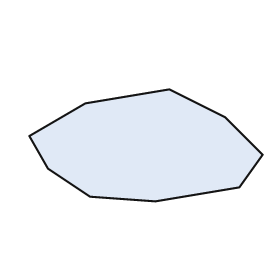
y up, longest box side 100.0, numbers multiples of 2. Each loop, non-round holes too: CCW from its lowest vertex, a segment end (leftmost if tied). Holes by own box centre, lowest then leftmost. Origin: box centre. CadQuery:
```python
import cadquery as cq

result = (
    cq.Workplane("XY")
    .moveTo(4.0, -24.0)
    .lineTo(40.0, -18.0)
    .lineTo(50.0, -4.0)
    .lineTo(34.0, 12.0)
    .lineTo(10.0, 24.0)
    .lineTo(-26.0, 18.0)
    .lineTo(-50.0, 4.0)
    .lineTo(-42.0, -10.0)
    .lineTo(-24.0, -22.0)
    .close()
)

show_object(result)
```